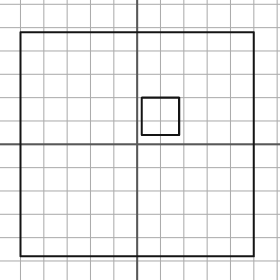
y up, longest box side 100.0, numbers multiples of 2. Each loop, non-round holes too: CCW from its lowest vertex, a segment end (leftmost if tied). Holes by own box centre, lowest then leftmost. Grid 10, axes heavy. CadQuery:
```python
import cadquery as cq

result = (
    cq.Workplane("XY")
    .moveTo(-50.0, -48.0)
    .lineTo(50.0, -48.0)
    .lineTo(50.0, 48.0)
    .lineTo(-50.0, 48.0)
    .close()
    .moveTo(2.0, 4.0)
    .lineTo(18.0, 4.0)
    .lineTo(18.0, 20.0)
    .lineTo(2.0, 20.0)
    .close()
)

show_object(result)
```